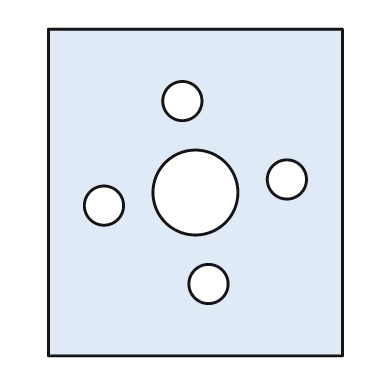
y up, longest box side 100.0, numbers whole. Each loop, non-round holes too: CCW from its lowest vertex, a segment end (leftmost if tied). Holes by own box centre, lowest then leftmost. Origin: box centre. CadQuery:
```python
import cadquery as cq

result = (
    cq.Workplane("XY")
    .moveTo(-45.0, -50.0)
    .lineTo(45.0, -50.0)
    .lineTo(45.0, 50.0)
    .lineTo(-45.0, 50.0)
    .close()
    .moveTo(4.0, -28.0)
    .circle(6.0)
    .moveTo(-28.0, -4.0)
    .circle(6.0)
    .moveTo(0.0, 0.0)
    .circle(13.0)
    .moveTo(28.0, 4.0)
    .circle(6.0)
    .moveTo(-4.0, 28.0)
    .circle(6.0)
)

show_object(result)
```